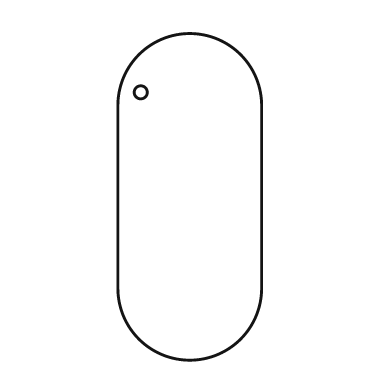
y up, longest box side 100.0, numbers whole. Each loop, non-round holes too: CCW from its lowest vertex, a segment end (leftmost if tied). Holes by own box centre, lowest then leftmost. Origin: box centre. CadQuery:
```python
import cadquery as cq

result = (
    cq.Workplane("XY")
    .moveTo(-22.0, -28.0)
    .threePointArc((0.0, -50.0), (22.0, -28.0))
    .lineTo(22.0, 28.0)
    .threePointArc((0.0, 50.0), (-22.0, 28.0))
    .close()
    .moveTo(-15.0, 32.0)
    .circle(2.0)
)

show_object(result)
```